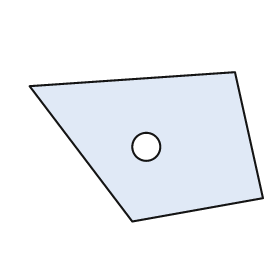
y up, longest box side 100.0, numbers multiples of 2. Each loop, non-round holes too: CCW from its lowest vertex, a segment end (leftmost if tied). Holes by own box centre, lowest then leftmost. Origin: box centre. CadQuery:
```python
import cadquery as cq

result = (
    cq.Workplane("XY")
    .moveTo(-6.0, -32.0)
    .lineTo(50.0, -22.0)
    .lineTo(38.0, 32.0)
    .lineTo(-50.0, 26.0)
    .close()
    .moveTo(0.0, 0.0)
    .circle(6.0)
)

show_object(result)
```